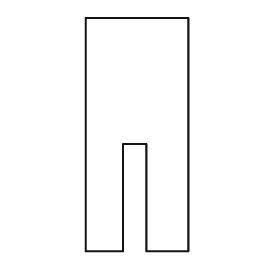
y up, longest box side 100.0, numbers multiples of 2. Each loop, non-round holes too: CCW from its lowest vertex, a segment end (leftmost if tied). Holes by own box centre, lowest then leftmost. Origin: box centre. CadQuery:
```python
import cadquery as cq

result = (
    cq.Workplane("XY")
    .moveTo(-22.0, -50.0)
    .lineTo(-6.0, -50.0)
    .lineTo(-6.0, -4.0)
    .lineTo(4.0, -4.0)
    .lineTo(4.0, -50.0)
    .lineTo(22.0, -50.0)
    .lineTo(22.0, 50.0)
    .lineTo(-22.0, 50.0)
    .close()
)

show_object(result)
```